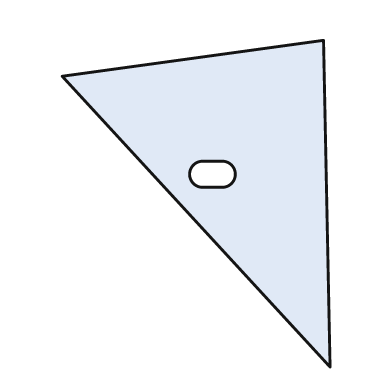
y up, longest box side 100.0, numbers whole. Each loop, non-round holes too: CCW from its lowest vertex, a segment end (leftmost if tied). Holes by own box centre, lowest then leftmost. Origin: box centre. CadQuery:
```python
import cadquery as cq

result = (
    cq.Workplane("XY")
    .moveTo(41.0, -50.0)
    .lineTo(39.0, 50.0)
    .lineTo(-41.0, 39.0)
    .close()
    .moveTo(2.0, 5.0)
    .lineTo(8.0, 5.0)
    .threePointArc((12.0, 9.0), (8.0, 13.0))
    .lineTo(2.0, 13.0)
    .threePointArc((-2.0, 9.0), (2.0, 5.0))
    .close()
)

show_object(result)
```